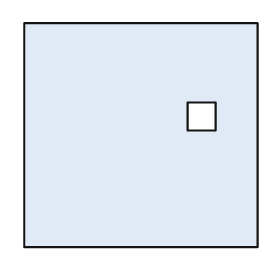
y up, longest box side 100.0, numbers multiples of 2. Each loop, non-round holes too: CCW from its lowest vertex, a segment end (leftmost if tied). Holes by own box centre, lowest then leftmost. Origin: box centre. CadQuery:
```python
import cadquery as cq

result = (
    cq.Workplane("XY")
    .moveTo(-50.0, -48.0)
    .lineTo(50.0, -48.0)
    .lineTo(50.0, 48.0)
    .lineTo(-50.0, 48.0)
    .close()
    .moveTo(20.0, 2.0)
    .lineTo(32.0, 2.0)
    .lineTo(32.0, 14.0)
    .lineTo(20.0, 14.0)
    .close()
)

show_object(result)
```